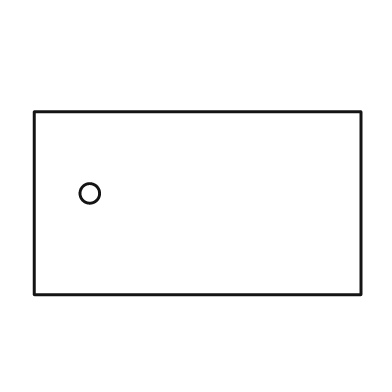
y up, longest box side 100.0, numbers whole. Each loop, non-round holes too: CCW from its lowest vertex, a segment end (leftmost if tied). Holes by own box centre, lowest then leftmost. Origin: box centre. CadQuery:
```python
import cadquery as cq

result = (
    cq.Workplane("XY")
    .moveTo(-50.0, -28.0)
    .lineTo(50.0, -28.0)
    .lineTo(50.0, 28.0)
    .lineTo(-50.0, 28.0)
    .close()
    .moveTo(-33.0, 3.0)
    .circle(3.0)
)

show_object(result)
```